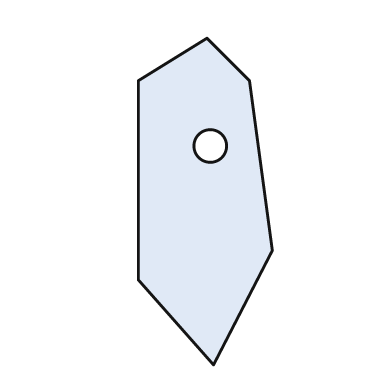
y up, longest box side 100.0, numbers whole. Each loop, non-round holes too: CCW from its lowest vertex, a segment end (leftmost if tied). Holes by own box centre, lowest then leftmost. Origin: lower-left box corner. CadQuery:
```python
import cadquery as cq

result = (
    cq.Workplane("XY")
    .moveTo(23.0, 0.0)
    .lineTo(41.0, 35.0)
    .lineTo(34.0, 87.0)
    .lineTo(21.0, 100.0)
    .lineTo(0.0, 87.0)
    .lineTo(0.0, 26.0)
    .close()
    .moveTo(22.0, 67.0)
    .circle(5.0)
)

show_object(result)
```